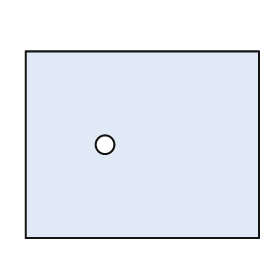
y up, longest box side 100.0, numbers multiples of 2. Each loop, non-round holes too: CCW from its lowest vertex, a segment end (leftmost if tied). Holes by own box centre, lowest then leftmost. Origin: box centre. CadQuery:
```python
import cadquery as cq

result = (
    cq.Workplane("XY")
    .moveTo(-50.0, -40.0)
    .lineTo(50.0, -40.0)
    .lineTo(50.0, 40.0)
    .lineTo(-50.0, 40.0)
    .close()
    .moveTo(-16.0, 0.0)
    .circle(4.0)
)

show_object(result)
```